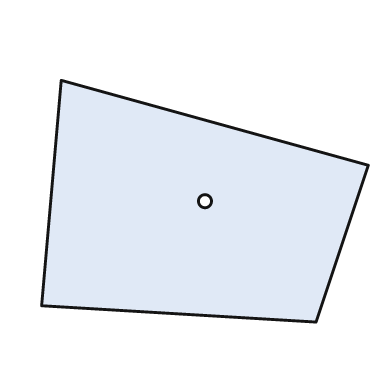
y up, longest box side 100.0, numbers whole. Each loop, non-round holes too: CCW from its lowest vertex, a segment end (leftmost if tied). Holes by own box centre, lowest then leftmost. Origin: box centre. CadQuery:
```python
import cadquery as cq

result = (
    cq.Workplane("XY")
    .moveTo(34.0, -37.0)
    .lineTo(50.0, 11.0)
    .lineTo(-44.0, 37.0)
    .lineTo(-50.0, -32.0)
    .close()
    .moveTo(0.0, 0.0)
    .circle(2.0)
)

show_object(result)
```